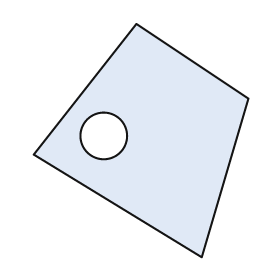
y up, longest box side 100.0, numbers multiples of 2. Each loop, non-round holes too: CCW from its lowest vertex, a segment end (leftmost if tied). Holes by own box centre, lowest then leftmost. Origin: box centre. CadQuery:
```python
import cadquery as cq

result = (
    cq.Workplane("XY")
    .moveTo(26.0, -50.0)
    .lineTo(46.0, 18.0)
    .lineTo(-2.0, 50.0)
    .lineTo(-46.0, -6.0)
    .close()
    .moveTo(-16.0, 2.0)
    .circle(10.0)
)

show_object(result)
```